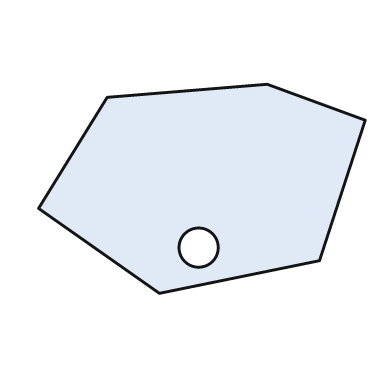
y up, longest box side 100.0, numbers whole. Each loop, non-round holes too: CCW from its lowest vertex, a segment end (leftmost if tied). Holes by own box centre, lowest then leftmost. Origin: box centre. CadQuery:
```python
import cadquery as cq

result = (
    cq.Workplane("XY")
    .moveTo(-13.0, -32.0)
    .lineTo(36.0, -22.0)
    .lineTo(50.0, 21.0)
    .lineTo(20.0, 32.0)
    .lineTo(-29.0, 28.0)
    .lineTo(-50.0, -6.0)
    .close()
    .moveTo(-1.0, -18.0)
    .circle(6.0)
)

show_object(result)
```